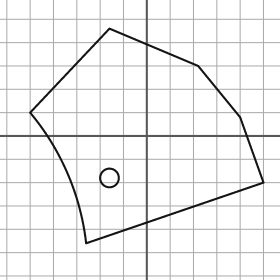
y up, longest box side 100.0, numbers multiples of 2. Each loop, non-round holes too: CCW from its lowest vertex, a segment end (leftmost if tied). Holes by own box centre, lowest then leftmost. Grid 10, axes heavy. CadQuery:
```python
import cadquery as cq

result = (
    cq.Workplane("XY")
    .moveTo(-26.0, -46.0)
    .lineTo(50.0, -20.0)
    .lineTo(40.0, 8.0)
    .lineTo(22.0, 30.0)
    .lineTo(-16.0, 46.0)
    .lineTo(-50.0, 10.0)
    .threePointArc((-34.0, -16.0), (-26.0, -46.0))
    .close()
    .moveTo(-16.0, -18.0)
    .circle(4.0)
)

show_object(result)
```